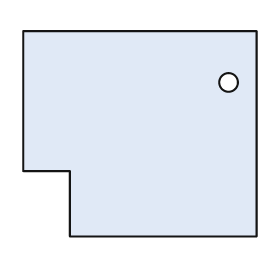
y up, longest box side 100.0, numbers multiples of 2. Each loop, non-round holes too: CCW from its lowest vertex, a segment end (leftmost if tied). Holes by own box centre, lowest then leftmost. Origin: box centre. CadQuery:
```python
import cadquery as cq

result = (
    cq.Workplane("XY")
    .moveTo(-30.0, -44.0)
    .lineTo(50.0, -44.0)
    .lineTo(50.0, 44.0)
    .lineTo(-50.0, 44.0)
    .lineTo(-50.0, -16.0)
    .lineTo(-30.0, -16.0)
    .close()
    .moveTo(38.0, 22.0)
    .circle(4.0)
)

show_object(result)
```